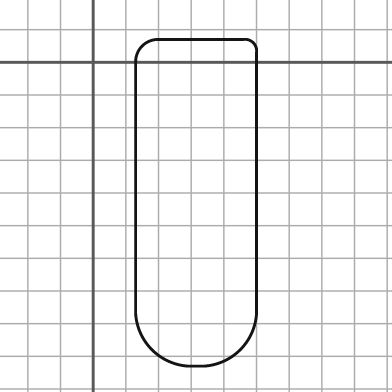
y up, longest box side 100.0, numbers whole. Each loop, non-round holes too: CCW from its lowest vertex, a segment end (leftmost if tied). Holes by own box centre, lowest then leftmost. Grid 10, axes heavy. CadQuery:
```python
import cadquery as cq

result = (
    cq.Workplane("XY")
    .moveTo(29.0, -93.0)
    .lineTo(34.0, -93.0)
    .threePointArc((45.0, -88.0), (50.0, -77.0))
    .lineTo(50.0, 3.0)
    .threePointArc((49.0, 6.0), (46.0, 7.0))
    .lineTo(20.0, 7.0)
    .threePointArc((15.0, 5.0), (13.0, 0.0))
    .lineTo(13.0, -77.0)
    .threePointArc((18.0, -88.0), (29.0, -93.0))
    .close()
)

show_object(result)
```